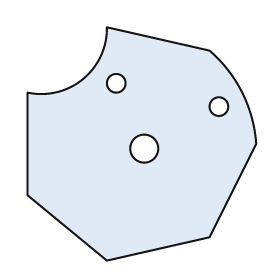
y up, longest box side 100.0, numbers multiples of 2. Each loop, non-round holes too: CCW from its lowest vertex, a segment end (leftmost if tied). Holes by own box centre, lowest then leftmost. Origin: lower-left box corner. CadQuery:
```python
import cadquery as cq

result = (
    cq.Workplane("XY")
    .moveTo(34.0, 0.0)
    .lineTo(78.0, 10.0)
    .lineTo(98.0, 50.0)
    .threePointArc((92.0, 72.0), (78.0, 90.0))
    .lineTo(34.0, 100.0)
    .threePointArc((24.0, 78.0), (0.0, 72.0))
    .lineTo(0.0, 28.0)
    .close()
    .moveTo(50.0, 48.0)
    .circle(6.0)
    .moveTo(82.0, 66.0)
    .circle(4.0)
    .moveTo(38.0, 76.0)
    .circle(4.0)
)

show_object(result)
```